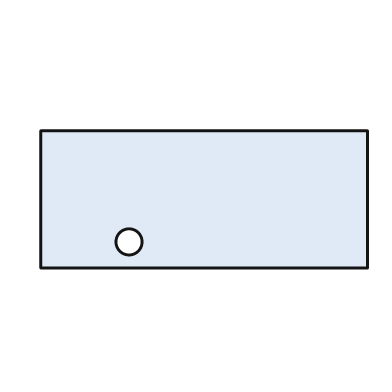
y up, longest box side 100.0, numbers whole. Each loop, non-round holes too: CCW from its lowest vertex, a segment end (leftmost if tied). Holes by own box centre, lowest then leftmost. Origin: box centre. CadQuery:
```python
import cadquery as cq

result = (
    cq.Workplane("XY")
    .moveTo(-50.0, -21.0)
    .lineTo(50.0, -21.0)
    .lineTo(50.0, 21.0)
    .lineTo(-50.0, 21.0)
    .close()
    .moveTo(-23.0, -13.0)
    .circle(4.0)
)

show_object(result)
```